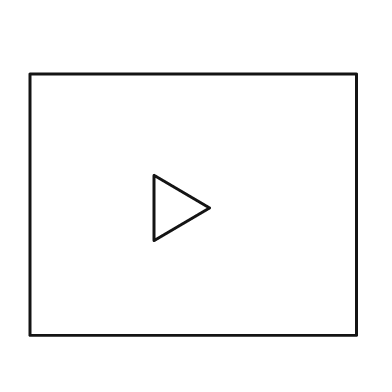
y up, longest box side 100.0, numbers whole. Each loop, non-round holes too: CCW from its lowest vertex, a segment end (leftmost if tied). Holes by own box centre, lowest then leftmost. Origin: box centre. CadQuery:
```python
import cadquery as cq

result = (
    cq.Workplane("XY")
    .moveTo(-50.0, -40.0)
    .lineTo(50.0, -40.0)
    .lineTo(50.0, 40.0)
    .lineTo(-50.0, 40.0)
    .close()
    .moveTo(-12.0, -11.0)
    .lineTo(5.0, -1.0)
    .lineTo(-12.0, 9.0)
    .close()
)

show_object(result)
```